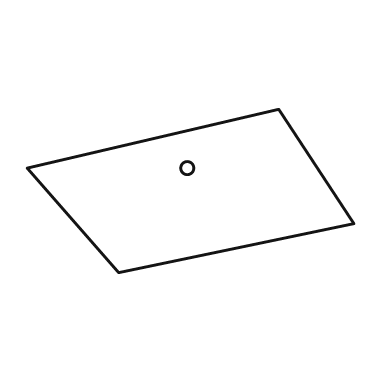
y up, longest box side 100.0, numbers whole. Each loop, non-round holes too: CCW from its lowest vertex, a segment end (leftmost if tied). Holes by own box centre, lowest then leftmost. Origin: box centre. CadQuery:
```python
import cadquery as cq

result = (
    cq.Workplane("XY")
    .moveTo(-22.0, -25.0)
    .lineTo(50.0, -10.0)
    .lineTo(27.0, 25.0)
    .lineTo(-50.0, 7.0)
    .close()
    .moveTo(-1.0, 7.0)
    .circle(2.0)
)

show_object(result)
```